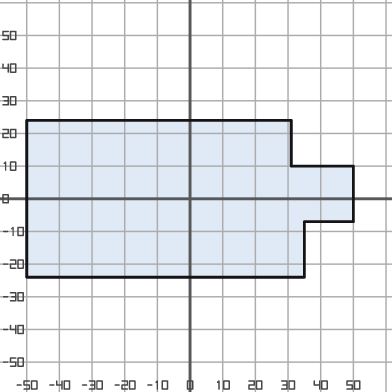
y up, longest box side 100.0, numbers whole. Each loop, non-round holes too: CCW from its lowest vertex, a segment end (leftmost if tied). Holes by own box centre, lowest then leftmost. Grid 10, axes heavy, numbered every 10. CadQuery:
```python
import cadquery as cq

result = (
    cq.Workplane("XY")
    .moveTo(-50.0, -24.0)
    .lineTo(35.0, -24.0)
    .lineTo(35.0, -7.0)
    .lineTo(50.0, -7.0)
    .lineTo(50.0, 10.0)
    .lineTo(31.0, 10.0)
    .lineTo(31.0, 24.0)
    .lineTo(-50.0, 24.0)
    .close()
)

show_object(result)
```